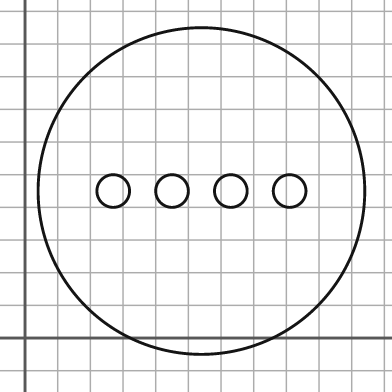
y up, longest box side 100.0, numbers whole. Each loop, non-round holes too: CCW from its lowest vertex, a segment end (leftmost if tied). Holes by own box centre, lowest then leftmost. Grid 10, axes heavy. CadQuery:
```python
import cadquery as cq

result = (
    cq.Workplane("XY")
    .moveTo(54.0, 45.0)
    .circle(50.0)
    .moveTo(27.0, 45.0)
    .circle(5.0)
    .moveTo(45.0, 45.0)
    .circle(5.0)
    .moveTo(63.0, 45.0)
    .circle(5.0)
    .moveTo(81.0, 45.0)
    .circle(5.0)
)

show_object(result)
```